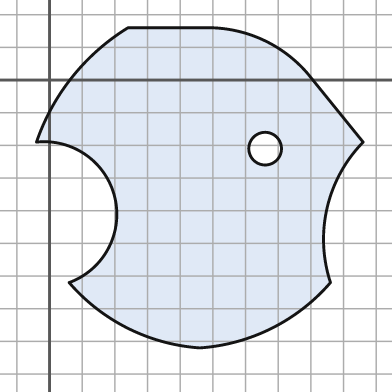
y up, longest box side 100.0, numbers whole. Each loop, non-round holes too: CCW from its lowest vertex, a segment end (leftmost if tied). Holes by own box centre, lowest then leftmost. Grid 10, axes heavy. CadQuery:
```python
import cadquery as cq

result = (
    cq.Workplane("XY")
    .moveTo(46.0, -82.0)
    .threePointArc((68.0, -76.0), (86.0, -62.0))
    .threePointArc((85.0, -39.0), (96.0, -19.0))
    .lineTo(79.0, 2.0)
    .threePointArc((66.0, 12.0), (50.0, 16.0))
    .lineTo(24.0, 16.0)
    .threePointArc((7.0, 1.0), (-4.0, -19.0))
    .threePointArc((20.0, -36.0), (6.0, -62.0))
    .threePointArc((24.0, -76.0), (46.0, -82.0))
    .close()
    .moveTo(66.0, -21.0)
    .circle(5.0)
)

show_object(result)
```